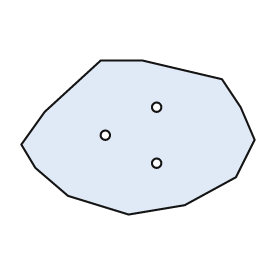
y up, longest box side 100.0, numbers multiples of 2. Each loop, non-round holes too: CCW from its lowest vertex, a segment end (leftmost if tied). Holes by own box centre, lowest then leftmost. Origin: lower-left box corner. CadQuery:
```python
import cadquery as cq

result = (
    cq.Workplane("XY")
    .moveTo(46.0, 0.0)
    .lineTo(70.0, 4.0)
    .lineTo(92.0, 16.0)
    .lineTo(100.0, 32.0)
    .lineTo(94.0, 46.0)
    .lineTo(86.0, 58.0)
    .lineTo(52.0, 66.0)
    .lineTo(34.0, 66.0)
    .lineTo(10.0, 44.0)
    .lineTo(0.0, 30.0)
    .lineTo(6.0, 20.0)
    .lineTo(20.0, 8.0)
    .close()
    .moveTo(58.0, 22.0)
    .circle(2.0)
    .moveTo(36.0, 34.0)
    .circle(2.0)
    .moveTo(58.0, 46.0)
    .circle(2.0)
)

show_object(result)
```